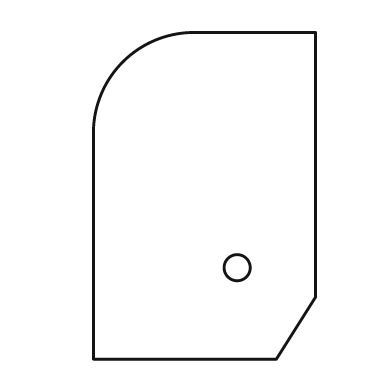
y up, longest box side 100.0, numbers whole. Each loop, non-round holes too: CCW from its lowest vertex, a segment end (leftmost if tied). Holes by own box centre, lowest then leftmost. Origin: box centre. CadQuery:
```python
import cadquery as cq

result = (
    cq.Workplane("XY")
    .moveTo(-34.0, -50.0)
    .lineTo(22.0, -50.0)
    .lineTo(34.0, -31.0)
    .lineTo(34.0, 50.0)
    .lineTo(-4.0, 50.0)
    .threePointArc((-25.0, 41.0), (-34.0, 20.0))
    .close()
    .moveTo(10.0, -22.0)
    .circle(4.0)
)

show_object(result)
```